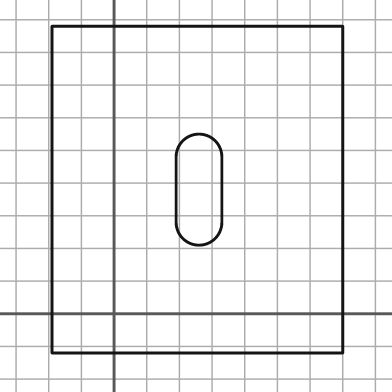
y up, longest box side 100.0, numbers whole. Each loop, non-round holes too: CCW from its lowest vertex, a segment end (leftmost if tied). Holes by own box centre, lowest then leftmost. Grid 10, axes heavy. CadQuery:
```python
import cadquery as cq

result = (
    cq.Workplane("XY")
    .moveTo(-19.0, -12.0)
    .lineTo(70.0, -12.0)
    .lineTo(70.0, 88.0)
    .lineTo(-19.0, 88.0)
    .close()
    .moveTo(19.0, 28.0)
    .threePointArc((26.0, 21.0), (33.0, 28.0))
    .lineTo(33.0, 48.0)
    .threePointArc((26.0, 55.0), (19.0, 48.0))
    .close()
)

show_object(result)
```